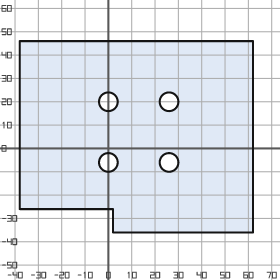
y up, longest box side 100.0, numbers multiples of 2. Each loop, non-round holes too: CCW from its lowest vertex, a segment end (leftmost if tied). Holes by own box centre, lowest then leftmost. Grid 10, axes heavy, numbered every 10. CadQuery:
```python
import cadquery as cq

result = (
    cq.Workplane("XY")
    .moveTo(2.0, -36.0)
    .lineTo(62.0, -36.0)
    .lineTo(62.0, 46.0)
    .lineTo(-38.0, 46.0)
    .lineTo(-38.0, -26.0)
    .lineTo(2.0, -26.0)
    .close()
    .moveTo(0.0, -6.0)
    .circle(4.0)
    .moveTo(26.0, -6.0)
    .circle(4.0)
    .moveTo(0.0, 20.0)
    .circle(4.0)
    .moveTo(26.0, 20.0)
    .circle(4.0)
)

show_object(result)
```